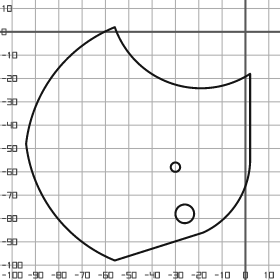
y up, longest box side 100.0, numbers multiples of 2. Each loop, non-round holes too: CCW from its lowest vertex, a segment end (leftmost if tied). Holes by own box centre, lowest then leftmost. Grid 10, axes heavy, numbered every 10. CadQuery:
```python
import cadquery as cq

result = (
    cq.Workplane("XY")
    .moveTo(-56.0, -98.0)
    .lineTo(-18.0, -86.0)
    .threePointArc((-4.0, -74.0), (2.0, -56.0))
    .lineTo(2.0, -18.0)
    .threePointArc((-32.0, -22.0), (-56.0, 2.0))
    .threePointArc((-82.0, -18.0), (-94.0, -48.0))
    .threePointArc((-82.0, -78.0), (-56.0, -98.0))
    .close()
    .moveTo(-26.0, -78.0)
    .circle(4.0)
    .moveTo(-30.0, -58.0)
    .circle(2.0)
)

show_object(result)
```